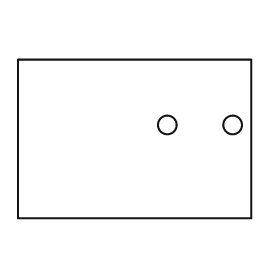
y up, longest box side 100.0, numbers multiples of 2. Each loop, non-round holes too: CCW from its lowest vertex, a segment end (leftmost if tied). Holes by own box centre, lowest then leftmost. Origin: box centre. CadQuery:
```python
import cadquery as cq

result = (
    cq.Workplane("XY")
    .moveTo(-50.0, -34.0)
    .lineTo(50.0, -34.0)
    .lineTo(50.0, 34.0)
    .lineTo(-50.0, 34.0)
    .close()
    .moveTo(14.0, 6.0)
    .circle(4.0)
    .moveTo(42.0, 6.0)
    .circle(4.0)
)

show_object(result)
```